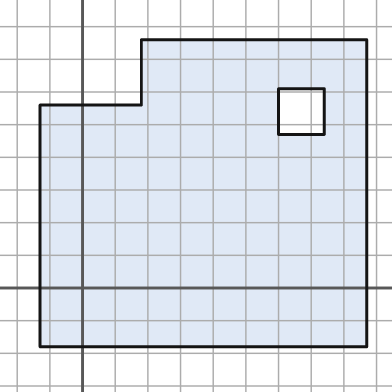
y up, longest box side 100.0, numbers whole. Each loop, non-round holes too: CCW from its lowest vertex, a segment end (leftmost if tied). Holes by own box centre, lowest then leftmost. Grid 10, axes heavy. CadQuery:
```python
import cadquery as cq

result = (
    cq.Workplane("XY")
    .moveTo(-13.0, -18.0)
    .lineTo(87.0, -18.0)
    .lineTo(87.0, 76.0)
    .lineTo(18.0, 76.0)
    .lineTo(18.0, 56.0)
    .lineTo(-13.0, 56.0)
    .close()
    .moveTo(60.0, 47.0)
    .lineTo(74.0, 47.0)
    .lineTo(74.0, 61.0)
    .lineTo(60.0, 61.0)
    .close()
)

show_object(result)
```